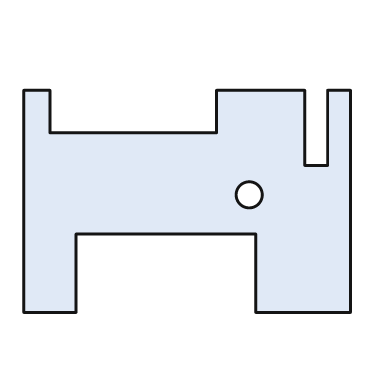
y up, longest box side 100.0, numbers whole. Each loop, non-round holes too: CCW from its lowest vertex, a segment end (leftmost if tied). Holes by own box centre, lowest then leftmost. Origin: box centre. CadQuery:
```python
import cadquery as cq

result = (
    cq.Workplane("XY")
    .moveTo(-50.0, -34.0)
    .lineTo(-34.0, -34.0)
    .lineTo(-34.0, -10.0)
    .lineTo(21.0, -10.0)
    .lineTo(21.0, -34.0)
    .lineTo(50.0, -34.0)
    .lineTo(50.0, 34.0)
    .lineTo(43.0, 34.0)
    .lineTo(43.0, 11.0)
    .lineTo(36.0, 11.0)
    .lineTo(36.0, 34.0)
    .lineTo(9.0, 34.0)
    .lineTo(9.0, 21.0)
    .lineTo(-42.0, 21.0)
    .lineTo(-42.0, 34.0)
    .lineTo(-50.0, 34.0)
    .close()
    .moveTo(19.0, 2.0)
    .circle(4.0)
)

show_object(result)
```